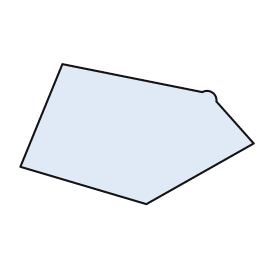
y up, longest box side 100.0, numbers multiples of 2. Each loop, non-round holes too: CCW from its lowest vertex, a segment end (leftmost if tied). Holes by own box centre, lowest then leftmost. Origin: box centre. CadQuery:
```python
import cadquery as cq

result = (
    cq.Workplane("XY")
    .moveTo(4.0, -30.0)
    .lineTo(50.0, -4.0)
    .lineTo(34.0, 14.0)
    .threePointArc((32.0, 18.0), (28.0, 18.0))
    .lineTo(-32.0, 30.0)
    .lineTo(-50.0, -14.0)
    .close()
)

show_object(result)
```